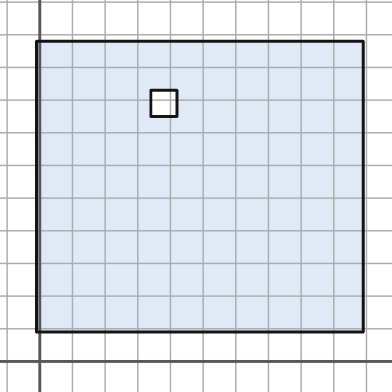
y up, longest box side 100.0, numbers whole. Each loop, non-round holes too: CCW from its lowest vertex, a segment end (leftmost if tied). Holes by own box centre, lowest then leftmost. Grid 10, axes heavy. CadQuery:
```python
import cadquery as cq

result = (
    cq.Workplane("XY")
    .moveTo(-1.0, 9.0)
    .lineTo(99.0, 9.0)
    .lineTo(99.0, 98.0)
    .lineTo(-1.0, 98.0)
    .close()
    .moveTo(34.0, 75.0)
    .lineTo(42.0, 75.0)
    .lineTo(42.0, 83.0)
    .lineTo(34.0, 83.0)
    .close()
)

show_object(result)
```